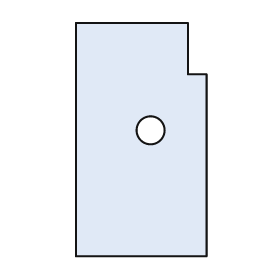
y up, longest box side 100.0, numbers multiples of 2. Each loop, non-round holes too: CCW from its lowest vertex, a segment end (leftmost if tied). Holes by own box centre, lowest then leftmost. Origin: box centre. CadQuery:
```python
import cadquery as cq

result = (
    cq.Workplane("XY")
    .moveTo(-28.0, -50.0)
    .lineTo(28.0, -50.0)
    .lineTo(28.0, 28.0)
    .lineTo(20.0, 28.0)
    .lineTo(20.0, 50.0)
    .lineTo(-28.0, 50.0)
    .close()
    .moveTo(4.0, 4.0)
    .circle(6.0)
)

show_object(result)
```